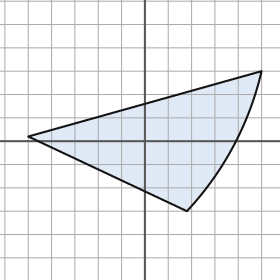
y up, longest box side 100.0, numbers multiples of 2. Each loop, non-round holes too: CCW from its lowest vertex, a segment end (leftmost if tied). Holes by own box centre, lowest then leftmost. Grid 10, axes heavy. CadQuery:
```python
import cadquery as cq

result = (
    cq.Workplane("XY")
    .moveTo(18.0, -30.0)
    .threePointArc((38.0, -2.0), (50.0, 30.0))
    .lineTo(-50.0, 2.0)
    .close()
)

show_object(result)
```